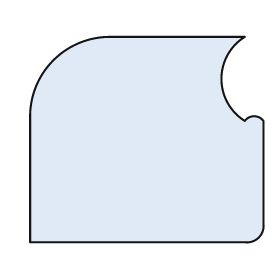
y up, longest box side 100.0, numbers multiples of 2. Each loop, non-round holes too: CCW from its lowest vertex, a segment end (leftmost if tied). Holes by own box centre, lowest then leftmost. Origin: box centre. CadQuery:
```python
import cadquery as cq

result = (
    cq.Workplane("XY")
    .moveTo(-50.0, -44.0)
    .lineTo(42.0, -44.0)
    .threePointArc((48.0, -42.0), (50.0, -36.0))
    .lineTo(50.0, 8.0)
    .threePointArc((46.0, 10.0), (42.0, 8.0))
    .threePointArc((32.0, 26.0), (42.0, 44.0))
    .lineTo(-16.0, 44.0)
    .threePointArc((-40.0, 34.0), (-50.0, 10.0))
    .close()
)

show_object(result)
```